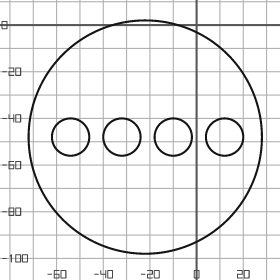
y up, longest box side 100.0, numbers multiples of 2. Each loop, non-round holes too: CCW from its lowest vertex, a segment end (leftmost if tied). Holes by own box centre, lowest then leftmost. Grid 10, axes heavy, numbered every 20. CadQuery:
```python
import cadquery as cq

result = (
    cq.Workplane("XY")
    .moveTo(-22.0, -48.0)
    .circle(50.0)
    .moveTo(-54.0, -48.0)
    .circle(8.0)
    .moveTo(-32.0, -48.0)
    .circle(8.0)
    .moveTo(-10.0, -48.0)
    .circle(8.0)
    .moveTo(12.0, -48.0)
    .circle(8.0)
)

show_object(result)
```